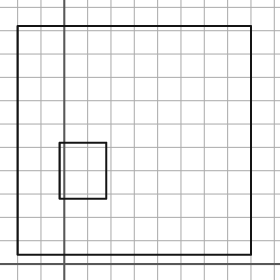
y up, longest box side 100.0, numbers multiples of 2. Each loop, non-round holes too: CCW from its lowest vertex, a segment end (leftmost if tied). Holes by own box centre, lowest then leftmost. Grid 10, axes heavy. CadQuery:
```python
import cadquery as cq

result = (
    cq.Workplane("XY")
    .moveTo(-20.0, 4.0)
    .lineTo(80.0, 4.0)
    .lineTo(80.0, 102.0)
    .lineTo(-20.0, 102.0)
    .close()
    .moveTo(-2.0, 28.0)
    .lineTo(18.0, 28.0)
    .lineTo(18.0, 52.0)
    .lineTo(-2.0, 52.0)
    .close()
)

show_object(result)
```